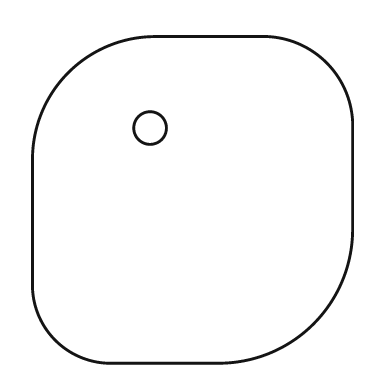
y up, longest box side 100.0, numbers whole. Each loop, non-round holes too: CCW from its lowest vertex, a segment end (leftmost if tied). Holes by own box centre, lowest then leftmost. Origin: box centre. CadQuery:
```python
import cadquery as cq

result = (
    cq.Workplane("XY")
    .moveTo(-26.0, -50.0)
    .lineTo(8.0, -50.0)
    .threePointArc((37.0, -38.0), (49.0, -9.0))
    .lineTo(49.0, 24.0)
    .threePointArc((41.0, 42.0), (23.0, 50.0))
    .lineTo(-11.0, 50.0)
    .threePointArc((-38.0, 39.0), (-49.0, 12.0))
    .lineTo(-49.0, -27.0)
    .threePointArc((-42.0, -43.0), (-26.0, -50.0))
    .close()
    .moveTo(-13.0, 22.0)
    .circle(5.0)
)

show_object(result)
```